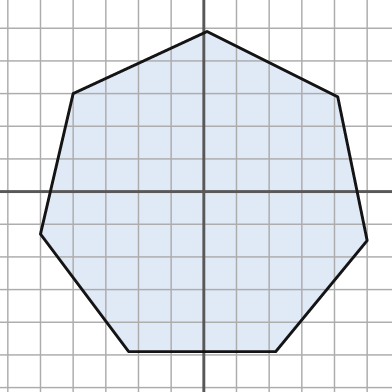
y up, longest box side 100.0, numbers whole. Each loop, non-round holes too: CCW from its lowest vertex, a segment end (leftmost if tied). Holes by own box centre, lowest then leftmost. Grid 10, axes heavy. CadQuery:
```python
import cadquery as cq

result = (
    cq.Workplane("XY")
    .moveTo(-23.0, -49.0)
    .lineTo(22.0, -49.0)
    .lineTo(50.0, -15.0)
    .lineTo(41.0, 29.0)
    .lineTo(1.0, 49.0)
    .lineTo(-40.0, 30.0)
    .lineTo(-50.0, -13.0)
    .close()
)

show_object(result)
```